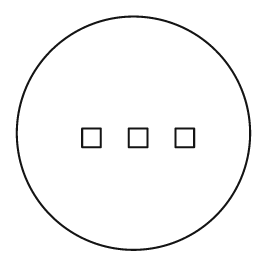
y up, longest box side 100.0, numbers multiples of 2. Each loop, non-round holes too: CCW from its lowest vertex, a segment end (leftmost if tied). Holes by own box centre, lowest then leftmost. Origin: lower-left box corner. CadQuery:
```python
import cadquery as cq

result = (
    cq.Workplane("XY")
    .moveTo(50.0, 50.0)
    .circle(50.0)
    .moveTo(28.0, 44.0)
    .lineTo(36.0, 44.0)
    .lineTo(36.0, 52.0)
    .lineTo(28.0, 52.0)
    .close()
    .moveTo(48.0, 44.0)
    .lineTo(56.0, 44.0)
    .lineTo(56.0, 52.0)
    .lineTo(48.0, 52.0)
    .close()
    .moveTo(68.0, 44.0)
    .lineTo(76.0, 44.0)
    .lineTo(76.0, 52.0)
    .lineTo(68.0, 52.0)
    .close()
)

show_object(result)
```